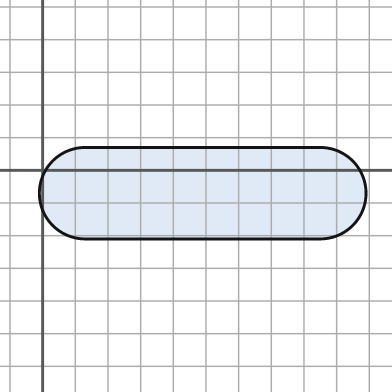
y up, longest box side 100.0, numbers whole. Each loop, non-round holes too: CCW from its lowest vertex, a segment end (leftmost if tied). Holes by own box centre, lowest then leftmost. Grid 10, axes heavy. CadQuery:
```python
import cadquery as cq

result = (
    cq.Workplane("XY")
    .moveTo(13.0, -21.0)
    .lineTo(85.0, -21.0)
    .threePointArc((99.0, -7.0), (85.0, 7.0))
    .lineTo(13.0, 7.0)
    .threePointArc((-1.0, -7.0), (13.0, -21.0))
    .close()
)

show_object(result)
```